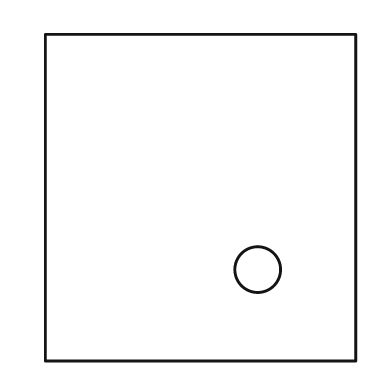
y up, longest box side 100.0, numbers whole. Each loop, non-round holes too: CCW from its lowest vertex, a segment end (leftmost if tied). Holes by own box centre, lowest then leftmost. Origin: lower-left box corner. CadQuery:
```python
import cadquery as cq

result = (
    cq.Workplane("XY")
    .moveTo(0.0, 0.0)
    .lineTo(95.0, 0.0)
    .lineTo(95.0, 100.0)
    .lineTo(0.0, 100.0)
    .close()
    .moveTo(65.0, 28.0)
    .circle(7.0)
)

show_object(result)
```